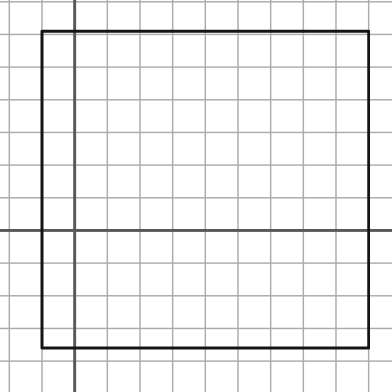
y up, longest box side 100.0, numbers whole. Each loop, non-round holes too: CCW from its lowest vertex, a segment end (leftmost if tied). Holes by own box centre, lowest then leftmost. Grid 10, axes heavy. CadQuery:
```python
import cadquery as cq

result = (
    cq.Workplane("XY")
    .moveTo(-10.0, -36.0)
    .lineTo(90.0, -36.0)
    .lineTo(90.0, 61.0)
    .lineTo(-10.0, 61.0)
    .close()
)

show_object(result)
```